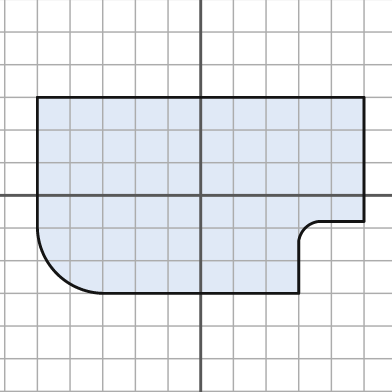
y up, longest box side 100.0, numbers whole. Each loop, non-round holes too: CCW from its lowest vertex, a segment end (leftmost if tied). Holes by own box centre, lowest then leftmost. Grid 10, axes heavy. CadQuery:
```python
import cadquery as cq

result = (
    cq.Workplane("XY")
    .moveTo(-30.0, -30.0)
    .lineTo(30.0, -30.0)
    .lineTo(30.0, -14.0)
    .threePointArc((32.0, -10.0), (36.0, -8.0))
    .lineTo(50.0, -8.0)
    .lineTo(50.0, 30.0)
    .lineTo(-50.0, 30.0)
    .lineTo(-50.0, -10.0)
    .threePointArc((-44.0, -24.0), (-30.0, -30.0))
    .close()
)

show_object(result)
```